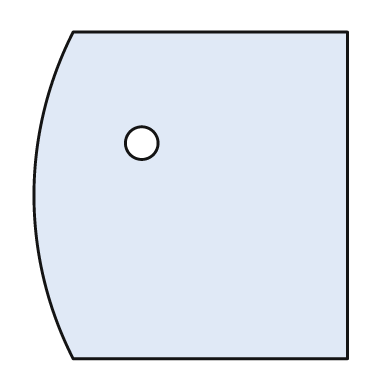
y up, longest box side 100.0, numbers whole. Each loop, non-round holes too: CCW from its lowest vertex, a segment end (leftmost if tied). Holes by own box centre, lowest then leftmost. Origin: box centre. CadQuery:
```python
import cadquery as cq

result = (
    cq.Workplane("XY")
    .moveTo(-36.0, -50.0)
    .lineTo(48.0, -50.0)
    .lineTo(48.0, 50.0)
    .lineTo(-36.0, 50.0)
    .threePointArc((-48.0, 0.0), (-36.0, -50.0))
    .close()
    .moveTo(-15.0, 16.0)
    .circle(5.0)
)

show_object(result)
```